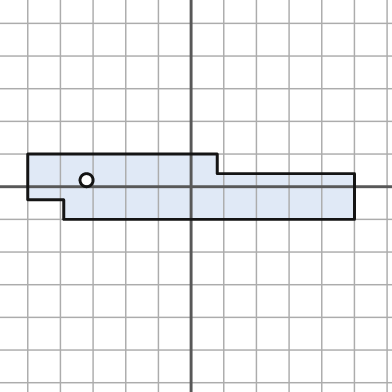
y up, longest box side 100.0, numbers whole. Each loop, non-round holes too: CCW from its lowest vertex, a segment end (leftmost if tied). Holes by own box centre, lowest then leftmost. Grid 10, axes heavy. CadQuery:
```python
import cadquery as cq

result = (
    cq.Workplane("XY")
    .moveTo(-39.0, -10.0)
    .lineTo(50.0, -10.0)
    .lineTo(50.0, 4.0)
    .lineTo(8.0, 4.0)
    .lineTo(8.0, 10.0)
    .lineTo(-50.0, 10.0)
    .lineTo(-50.0, -4.0)
    .lineTo(-39.0, -4.0)
    .close()
    .moveTo(-32.0, 2.0)
    .circle(2.0)
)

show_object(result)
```